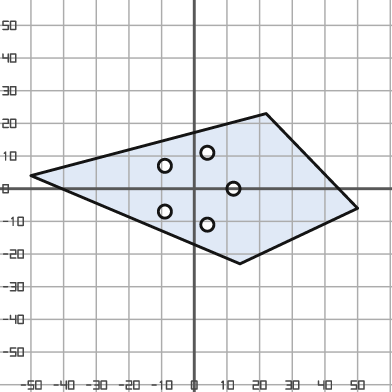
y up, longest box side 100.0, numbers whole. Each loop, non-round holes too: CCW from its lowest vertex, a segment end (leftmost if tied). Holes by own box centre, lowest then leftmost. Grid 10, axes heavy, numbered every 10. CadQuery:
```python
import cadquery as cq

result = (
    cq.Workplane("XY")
    .moveTo(14.0, -23.0)
    .lineTo(50.0, -6.0)
    .lineTo(22.0, 23.0)
    .lineTo(-50.0, 4.0)
    .close()
    .moveTo(4.0, -11.0)
    .circle(2.0)
    .moveTo(-9.0, -7.0)
    .circle(2.0)
    .moveTo(12.0, 0.0)
    .circle(2.0)
    .moveTo(-9.0, 7.0)
    .circle(2.0)
    .moveTo(4.0, 11.0)
    .circle(2.0)
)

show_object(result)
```